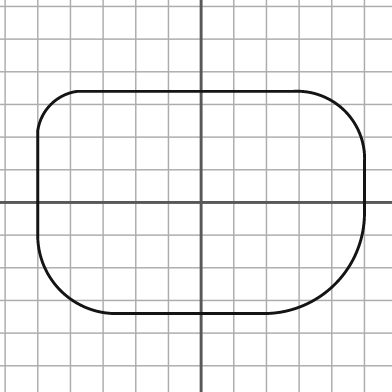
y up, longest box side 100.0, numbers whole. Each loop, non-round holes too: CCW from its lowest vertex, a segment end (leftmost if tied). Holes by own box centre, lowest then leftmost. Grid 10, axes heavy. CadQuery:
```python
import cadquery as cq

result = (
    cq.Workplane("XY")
    .moveTo(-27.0, -34.0)
    .lineTo(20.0, -34.0)
    .threePointArc((41.0, -25.0), (50.0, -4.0))
    .lineTo(50.0, 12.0)
    .threePointArc((44.0, 28.0), (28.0, 34.0))
    .lineTo(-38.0, 34.0)
    .threePointArc((-46.0, 30.0), (-50.0, 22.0))
    .lineTo(-50.0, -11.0)
    .threePointArc((-43.0, -27.0), (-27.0, -34.0))
    .close()
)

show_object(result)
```